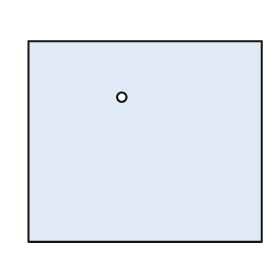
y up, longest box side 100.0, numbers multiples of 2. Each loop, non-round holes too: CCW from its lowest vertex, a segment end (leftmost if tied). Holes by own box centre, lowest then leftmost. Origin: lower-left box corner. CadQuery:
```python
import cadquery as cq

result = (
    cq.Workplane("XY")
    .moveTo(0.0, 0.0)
    .lineTo(100.0, 0.0)
    .lineTo(100.0, 86.0)
    .lineTo(0.0, 86.0)
    .close()
    .moveTo(40.0, 62.0)
    .circle(2.0)
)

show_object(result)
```